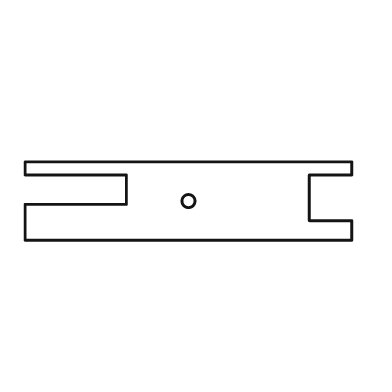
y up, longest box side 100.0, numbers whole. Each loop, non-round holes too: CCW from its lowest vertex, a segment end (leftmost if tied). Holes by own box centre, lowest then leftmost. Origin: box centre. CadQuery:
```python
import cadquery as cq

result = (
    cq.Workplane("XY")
    .moveTo(-50.0, -12.0)
    .lineTo(50.0, -12.0)
    .lineTo(50.0, -6.0)
    .lineTo(37.0, -6.0)
    .lineTo(37.0, 8.0)
    .lineTo(50.0, 8.0)
    .lineTo(50.0, 12.0)
    .lineTo(-50.0, 12.0)
    .lineTo(-50.0, 8.0)
    .lineTo(-19.0, 8.0)
    .lineTo(-19.0, -1.0)
    .lineTo(-50.0, -1.0)
    .close()
    .moveTo(0.0, 0.0)
    .circle(2.0)
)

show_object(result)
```